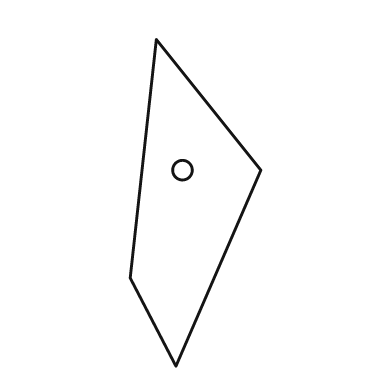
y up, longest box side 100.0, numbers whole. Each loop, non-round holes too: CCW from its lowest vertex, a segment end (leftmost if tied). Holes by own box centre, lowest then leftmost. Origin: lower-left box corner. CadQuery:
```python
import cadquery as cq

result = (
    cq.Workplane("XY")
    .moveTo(14.0, 0.0)
    .lineTo(40.0, 60.0)
    .lineTo(8.0, 100.0)
    .lineTo(0.0, 27.0)
    .close()
    .moveTo(16.0, 60.0)
    .circle(3.0)
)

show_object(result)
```